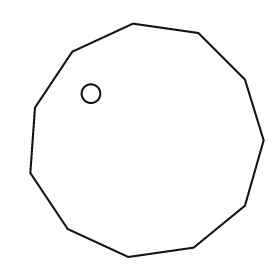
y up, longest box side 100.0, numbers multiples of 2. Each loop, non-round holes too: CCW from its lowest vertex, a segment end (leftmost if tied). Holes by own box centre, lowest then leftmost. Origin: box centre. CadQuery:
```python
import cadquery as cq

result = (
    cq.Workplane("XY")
    .moveTo(-8.0, -50.0)
    .lineTo(20.0, -46.0)
    .lineTo(42.0, -28.0)
    .lineTo(50.0, 0.0)
    .lineTo(42.0, 26.0)
    .lineTo(22.0, 46.0)
    .lineTo(-6.0, 50.0)
    .lineTo(-32.0, 38.0)
    .lineTo(-48.0, 14.0)
    .lineTo(-50.0, -14.0)
    .lineTo(-34.0, -38.0)
    .close()
    .moveTo(-24.0, 20.0)
    .circle(4.0)
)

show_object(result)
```